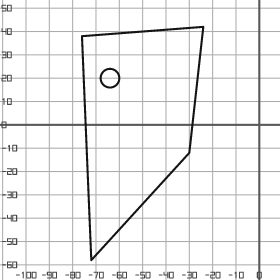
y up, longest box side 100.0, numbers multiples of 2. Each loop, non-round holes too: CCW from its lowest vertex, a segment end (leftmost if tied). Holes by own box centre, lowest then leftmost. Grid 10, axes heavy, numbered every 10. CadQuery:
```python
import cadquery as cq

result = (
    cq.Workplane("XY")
    .moveTo(-72.0, -58.0)
    .lineTo(-30.0, -12.0)
    .lineTo(-24.0, 42.0)
    .lineTo(-76.0, 38.0)
    .close()
    .moveTo(-64.0, 20.0)
    .circle(4.0)
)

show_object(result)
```